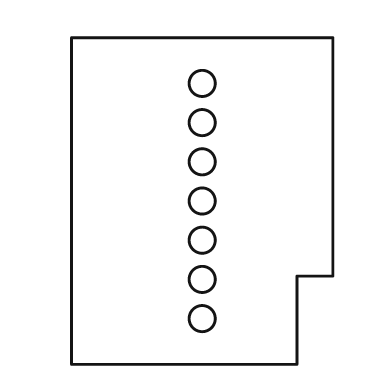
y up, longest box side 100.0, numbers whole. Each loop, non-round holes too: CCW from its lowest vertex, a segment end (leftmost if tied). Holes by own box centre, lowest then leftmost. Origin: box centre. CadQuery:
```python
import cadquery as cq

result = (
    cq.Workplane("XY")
    .moveTo(-40.0, -50.0)
    .lineTo(29.0, -50.0)
    .lineTo(29.0, -23.0)
    .lineTo(40.0, -23.0)
    .lineTo(40.0, 50.0)
    .lineTo(-40.0, 50.0)
    .close()
    .moveTo(0.0, -36.0)
    .circle(4.0)
    .moveTo(0.0, -24.0)
    .circle(4.0)
    .moveTo(0.0, -12.0)
    .circle(4.0)
    .moveTo(0.0, 0.0)
    .circle(4.0)
    .moveTo(0.0, 12.0)
    .circle(4.0)
    .moveTo(0.0, 24.0)
    .circle(4.0)
    .moveTo(0.0, 36.0)
    .circle(4.0)
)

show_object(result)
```